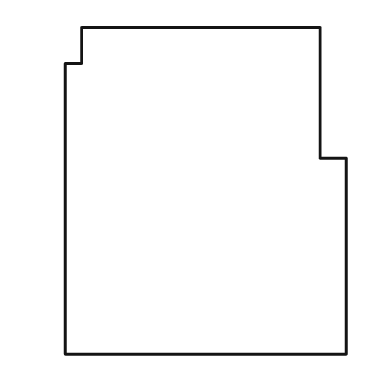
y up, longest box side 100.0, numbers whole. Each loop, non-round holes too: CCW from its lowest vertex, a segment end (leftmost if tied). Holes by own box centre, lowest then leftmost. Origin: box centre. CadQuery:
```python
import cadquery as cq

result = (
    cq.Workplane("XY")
    .moveTo(-43.0, -50.0)
    .lineTo(43.0, -50.0)
    .lineTo(43.0, 10.0)
    .lineTo(35.0, 10.0)
    .lineTo(35.0, 50.0)
    .lineTo(-38.0, 50.0)
    .lineTo(-38.0, 39.0)
    .lineTo(-43.0, 39.0)
    .close()
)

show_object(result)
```